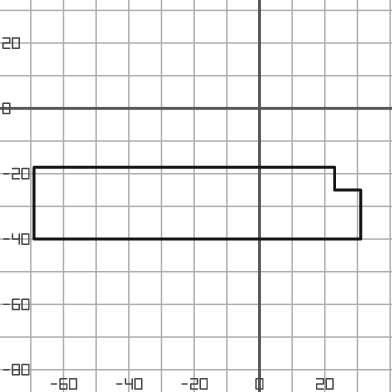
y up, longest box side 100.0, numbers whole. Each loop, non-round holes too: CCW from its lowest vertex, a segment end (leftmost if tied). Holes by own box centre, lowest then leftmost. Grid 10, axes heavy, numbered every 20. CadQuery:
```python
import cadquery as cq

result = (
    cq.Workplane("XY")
    .moveTo(-69.0, -40.0)
    .lineTo(31.0, -40.0)
    .lineTo(31.0, -25.0)
    .lineTo(23.0, -25.0)
    .lineTo(23.0, -18.0)
    .lineTo(-69.0, -18.0)
    .close()
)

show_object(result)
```